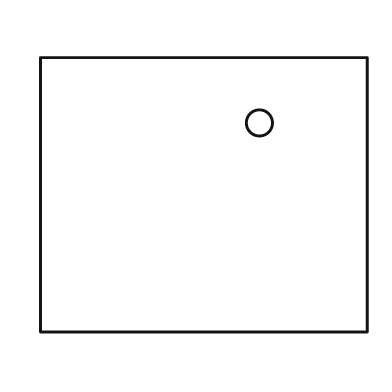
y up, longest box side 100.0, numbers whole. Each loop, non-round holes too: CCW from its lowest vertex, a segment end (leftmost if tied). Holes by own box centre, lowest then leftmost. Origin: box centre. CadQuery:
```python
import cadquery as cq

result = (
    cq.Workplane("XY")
    .moveTo(-50.0, -42.0)
    .lineTo(50.0, -42.0)
    .lineTo(50.0, 42.0)
    .lineTo(-50.0, 42.0)
    .close()
    .moveTo(17.0, 22.0)
    .circle(4.0)
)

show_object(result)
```